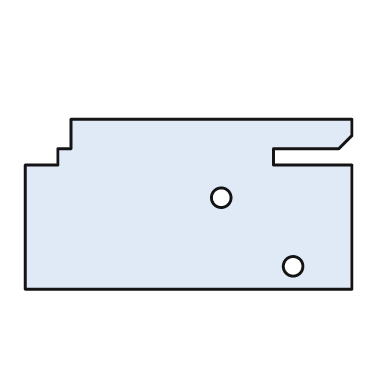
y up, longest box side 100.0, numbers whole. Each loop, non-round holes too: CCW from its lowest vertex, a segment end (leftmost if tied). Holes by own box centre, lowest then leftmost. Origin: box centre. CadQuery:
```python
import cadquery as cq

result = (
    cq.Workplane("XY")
    .moveTo(-50.0, -26.0)
    .lineTo(50.0, -26.0)
    .lineTo(50.0, 12.0)
    .lineTo(26.0, 12.0)
    .lineTo(26.0, 17.0)
    .lineTo(46.0, 17.0)
    .lineTo(50.0, 21.0)
    .lineTo(50.0, 26.0)
    .lineTo(-36.0, 26.0)
    .lineTo(-36.0, 17.0)
    .lineTo(-40.0, 17.0)
    .lineTo(-40.0, 12.0)
    .lineTo(-50.0, 12.0)
    .close()
    .moveTo(32.0, -19.0)
    .circle(3.0)
    .moveTo(10.0, 2.0)
    .circle(3.0)
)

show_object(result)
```